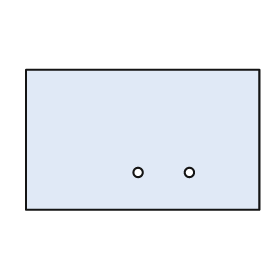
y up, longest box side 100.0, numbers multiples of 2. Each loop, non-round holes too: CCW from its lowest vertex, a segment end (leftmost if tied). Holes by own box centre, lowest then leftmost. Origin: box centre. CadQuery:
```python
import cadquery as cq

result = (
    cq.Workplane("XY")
    .moveTo(-50.0, -30.0)
    .lineTo(50.0, -30.0)
    .lineTo(50.0, 30.0)
    .lineTo(-50.0, 30.0)
    .close()
    .moveTo(-2.0, -14.0)
    .circle(2.0)
    .moveTo(20.0, -14.0)
    .circle(2.0)
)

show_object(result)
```